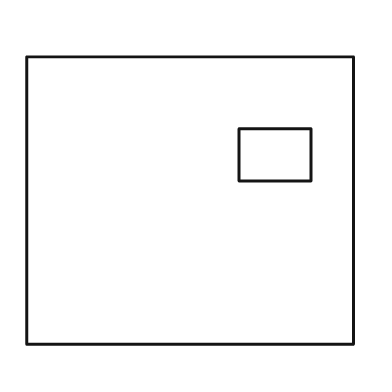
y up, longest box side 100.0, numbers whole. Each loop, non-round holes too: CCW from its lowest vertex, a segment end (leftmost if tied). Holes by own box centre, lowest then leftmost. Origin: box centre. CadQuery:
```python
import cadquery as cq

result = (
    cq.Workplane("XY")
    .moveTo(-50.0, -44.0)
    .lineTo(50.0, -44.0)
    .lineTo(50.0, 44.0)
    .lineTo(-50.0, 44.0)
    .close()
    .moveTo(15.0, 6.0)
    .lineTo(37.0, 6.0)
    .lineTo(37.0, 22.0)
    .lineTo(15.0, 22.0)
    .close()
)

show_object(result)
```